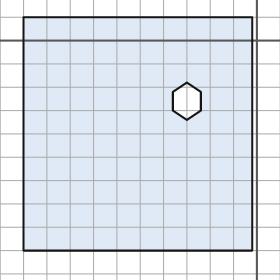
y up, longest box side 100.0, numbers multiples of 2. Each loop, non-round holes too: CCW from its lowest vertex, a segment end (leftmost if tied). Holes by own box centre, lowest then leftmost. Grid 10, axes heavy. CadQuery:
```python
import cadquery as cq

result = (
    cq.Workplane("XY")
    .moveTo(-100.0, -90.0)
    .lineTo(-2.0, -90.0)
    .lineTo(-2.0, 10.0)
    .lineTo(-100.0, 10.0)
    .close()
    .moveTo(-30.0, -34.0)
    .lineTo(-24.0, -30.0)
    .lineTo(-24.0, -22.0)
    .lineTo(-30.0, -18.0)
    .lineTo(-36.0, -22.0)
    .lineTo(-36.0, -30.0)
    .close()
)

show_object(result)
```